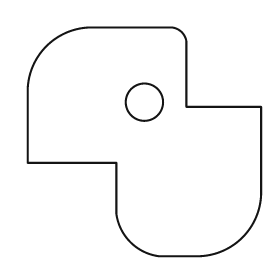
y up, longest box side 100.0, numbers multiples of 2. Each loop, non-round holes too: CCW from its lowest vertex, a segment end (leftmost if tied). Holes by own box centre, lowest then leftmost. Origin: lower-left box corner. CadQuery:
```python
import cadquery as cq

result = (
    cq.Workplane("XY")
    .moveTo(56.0, 0.0)
    .lineTo(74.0, 0.0)
    .threePointArc((92.0, 8.0), (100.0, 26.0))
    .lineTo(100.0, 64.0)
    .lineTo(68.0, 64.0)
    .lineTo(68.0, 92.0)
    .threePointArc((66.0, 96.0), (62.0, 98.0))
    .lineTo(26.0, 98.0)
    .threePointArc((8.0, 90.0), (0.0, 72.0))
    .lineTo(0.0, 40.0)
    .lineTo(38.0, 40.0)
    .lineTo(38.0, 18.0)
    .threePointArc((44.0, 6.0), (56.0, 0.0))
    .close()
    .moveTo(50.0, 66.0)
    .circle(8.0)
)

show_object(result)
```